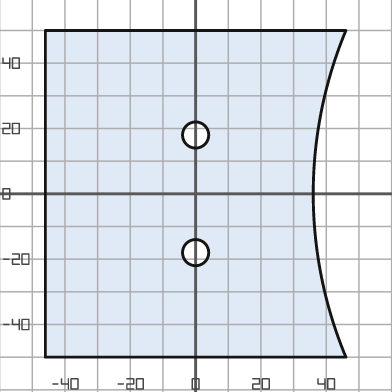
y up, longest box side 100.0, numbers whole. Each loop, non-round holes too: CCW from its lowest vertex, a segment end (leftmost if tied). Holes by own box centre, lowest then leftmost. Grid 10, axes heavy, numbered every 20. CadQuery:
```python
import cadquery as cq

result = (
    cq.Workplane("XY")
    .moveTo(-46.0, -50.0)
    .lineTo(46.0, -50.0)
    .threePointArc((36.0, 0.0), (46.0, 50.0))
    .lineTo(-46.0, 50.0)
    .close()
    .moveTo(0.0, -18.0)
    .circle(4.0)
    .moveTo(0.0, 18.0)
    .circle(4.0)
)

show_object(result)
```